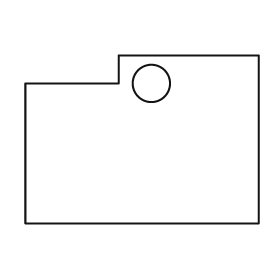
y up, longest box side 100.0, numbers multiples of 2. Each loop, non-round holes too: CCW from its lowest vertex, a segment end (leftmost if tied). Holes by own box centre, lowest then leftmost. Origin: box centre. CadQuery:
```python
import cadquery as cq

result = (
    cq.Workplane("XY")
    .moveTo(-50.0, -36.0)
    .lineTo(50.0, -36.0)
    .lineTo(50.0, 36.0)
    .lineTo(-10.0, 36.0)
    .lineTo(-10.0, 24.0)
    .lineTo(-50.0, 24.0)
    .close()
    .moveTo(4.0, 24.0)
    .circle(8.0)
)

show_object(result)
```